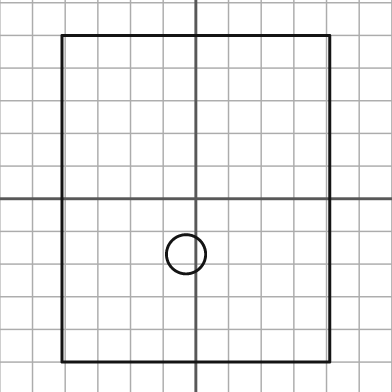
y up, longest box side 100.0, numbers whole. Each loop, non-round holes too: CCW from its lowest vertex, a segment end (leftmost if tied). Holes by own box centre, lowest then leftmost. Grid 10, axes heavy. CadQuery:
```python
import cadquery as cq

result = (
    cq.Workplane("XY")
    .moveTo(-41.0, -50.0)
    .lineTo(41.0, -50.0)
    .lineTo(41.0, 50.0)
    .lineTo(-41.0, 50.0)
    .close()
    .moveTo(-3.0, -17.0)
    .circle(6.0)
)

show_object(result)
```